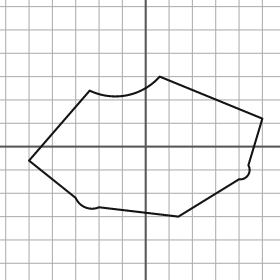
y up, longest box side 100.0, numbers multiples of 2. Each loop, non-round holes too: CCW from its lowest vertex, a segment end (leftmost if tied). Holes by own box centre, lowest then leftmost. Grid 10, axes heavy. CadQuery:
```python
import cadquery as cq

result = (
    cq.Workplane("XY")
    .moveTo(14.0, -30.0)
    .lineTo(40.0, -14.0)
    .threePointArc((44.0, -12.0), (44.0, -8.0))
    .lineTo(50.0, 12.0)
    .lineTo(6.0, 30.0)
    .threePointArc((-8.0, 22.0), (-24.0, 24.0))
    .lineTo(-50.0, -6.0)
    .lineTo(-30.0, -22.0)
    .threePointArc((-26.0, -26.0), (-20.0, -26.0))
    .close()
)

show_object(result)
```